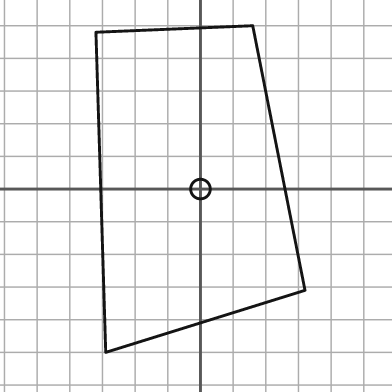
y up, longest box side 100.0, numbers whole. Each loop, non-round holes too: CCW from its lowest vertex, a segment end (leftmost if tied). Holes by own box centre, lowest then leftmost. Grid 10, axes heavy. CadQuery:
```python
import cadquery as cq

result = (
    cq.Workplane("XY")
    .moveTo(-29.0, -50.0)
    .lineTo(32.0, -31.0)
    .lineTo(16.0, 50.0)
    .lineTo(-32.0, 48.0)
    .close()
    .moveTo(0.0, 0.0)
    .circle(3.0)
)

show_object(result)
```